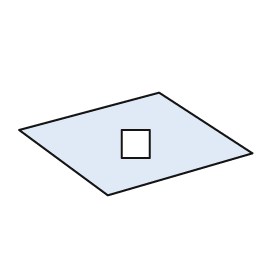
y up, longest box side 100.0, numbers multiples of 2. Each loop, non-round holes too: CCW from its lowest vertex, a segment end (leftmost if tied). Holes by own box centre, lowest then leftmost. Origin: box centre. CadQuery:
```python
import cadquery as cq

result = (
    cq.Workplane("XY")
    .moveTo(-12.0, -22.0)
    .lineTo(50.0, -4.0)
    .lineTo(10.0, 22.0)
    .lineTo(-50.0, 6.0)
    .close()
    .moveTo(-6.0, -6.0)
    .lineTo(6.0, -6.0)
    .lineTo(6.0, 6.0)
    .lineTo(-6.0, 6.0)
    .close()
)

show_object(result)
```